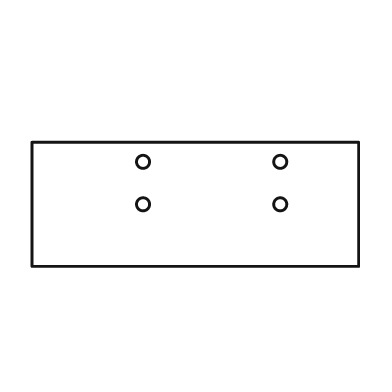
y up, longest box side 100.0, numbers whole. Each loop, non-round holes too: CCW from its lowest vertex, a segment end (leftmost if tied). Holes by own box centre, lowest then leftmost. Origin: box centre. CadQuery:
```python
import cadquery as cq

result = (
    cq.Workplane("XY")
    .moveTo(-50.0, -19.0)
    .lineTo(50.0, -19.0)
    .lineTo(50.0, 19.0)
    .lineTo(-50.0, 19.0)
    .close()
    .moveTo(-16.0, 0.0)
    .circle(2.0)
    .moveTo(26.0, 0.0)
    .circle(2.0)
    .moveTo(-16.0, 13.0)
    .circle(2.0)
    .moveTo(26.0, 13.0)
    .circle(2.0)
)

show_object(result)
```